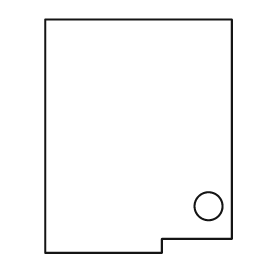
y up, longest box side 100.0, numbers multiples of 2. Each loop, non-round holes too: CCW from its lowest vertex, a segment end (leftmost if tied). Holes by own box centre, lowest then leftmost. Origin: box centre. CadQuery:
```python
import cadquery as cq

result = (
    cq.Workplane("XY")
    .moveTo(-40.0, -50.0)
    .lineTo(10.0, -50.0)
    .lineTo(10.0, -44.0)
    .lineTo(40.0, -44.0)
    .lineTo(40.0, 50.0)
    .lineTo(-40.0, 50.0)
    .close()
    .moveTo(30.0, -30.0)
    .circle(6.0)
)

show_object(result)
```